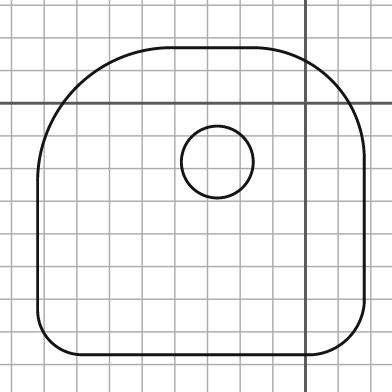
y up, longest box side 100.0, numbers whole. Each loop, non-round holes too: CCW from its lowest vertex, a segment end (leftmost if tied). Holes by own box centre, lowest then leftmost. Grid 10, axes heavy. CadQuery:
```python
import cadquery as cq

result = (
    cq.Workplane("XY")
    .moveTo(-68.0, -77.0)
    .lineTo(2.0, -77.0)
    .threePointArc((13.0, -72.0), (18.0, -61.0))
    .lineTo(18.0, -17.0)
    .threePointArc((8.0, 7.0), (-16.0, 17.0))
    .lineTo(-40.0, 17.0)
    .threePointArc((-70.0, 5.0), (-82.0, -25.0))
    .lineTo(-82.0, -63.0)
    .threePointArc((-78.0, -73.0), (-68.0, -77.0))
    .close()
    .moveTo(-27.0, -18.0)
    .circle(11.0)
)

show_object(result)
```